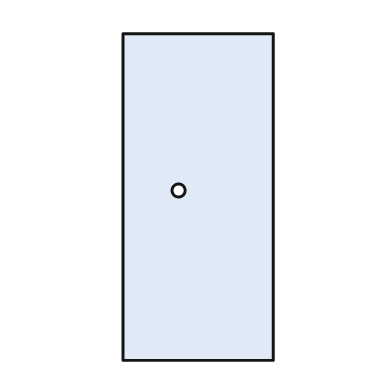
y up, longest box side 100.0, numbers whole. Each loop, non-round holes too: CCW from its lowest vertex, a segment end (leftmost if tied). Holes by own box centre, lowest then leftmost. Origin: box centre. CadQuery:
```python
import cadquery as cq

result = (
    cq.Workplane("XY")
    .moveTo(-23.0, -50.0)
    .lineTo(23.0, -50.0)
    .lineTo(23.0, 50.0)
    .lineTo(-23.0, 50.0)
    .close()
    .moveTo(-6.0, 2.0)
    .circle(2.0)
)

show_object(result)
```